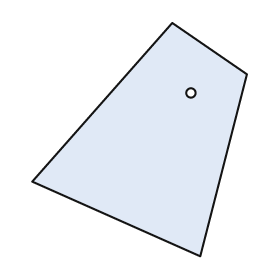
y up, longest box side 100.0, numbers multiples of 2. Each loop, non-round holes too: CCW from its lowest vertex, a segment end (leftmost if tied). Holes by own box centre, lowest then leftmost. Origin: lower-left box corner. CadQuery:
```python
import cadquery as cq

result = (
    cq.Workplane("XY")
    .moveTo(72.0, 0.0)
    .lineTo(92.0, 78.0)
    .lineTo(60.0, 100.0)
    .lineTo(0.0, 32.0)
    .close()
    .moveTo(68.0, 70.0)
    .circle(2.0)
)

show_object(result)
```